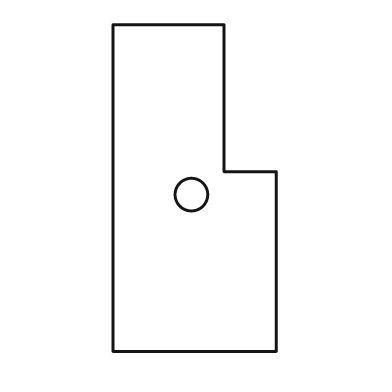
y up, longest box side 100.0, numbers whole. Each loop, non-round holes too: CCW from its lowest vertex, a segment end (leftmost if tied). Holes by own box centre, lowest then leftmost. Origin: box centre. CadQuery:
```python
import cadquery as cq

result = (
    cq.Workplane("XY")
    .moveTo(-25.0, -50.0)
    .lineTo(25.0, -50.0)
    .lineTo(25.0, 5.0)
    .lineTo(9.0, 5.0)
    .lineTo(9.0, 50.0)
    .lineTo(-25.0, 50.0)
    .close()
    .moveTo(-1.0, -2.0)
    .circle(5.0)
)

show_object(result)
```